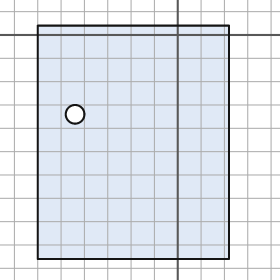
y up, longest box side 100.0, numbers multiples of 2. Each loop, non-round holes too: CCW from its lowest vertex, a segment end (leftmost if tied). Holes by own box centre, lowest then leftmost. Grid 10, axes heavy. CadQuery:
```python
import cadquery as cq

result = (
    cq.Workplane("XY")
    .moveTo(-60.0, -96.0)
    .lineTo(22.0, -96.0)
    .lineTo(22.0, 4.0)
    .lineTo(-60.0, 4.0)
    .close()
    .moveTo(-44.0, -34.0)
    .circle(4.0)
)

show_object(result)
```